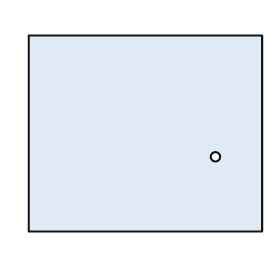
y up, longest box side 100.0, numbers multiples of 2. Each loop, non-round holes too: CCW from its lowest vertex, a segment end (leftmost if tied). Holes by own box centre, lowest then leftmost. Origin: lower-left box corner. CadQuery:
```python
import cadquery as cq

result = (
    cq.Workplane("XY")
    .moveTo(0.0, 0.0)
    .lineTo(100.0, 0.0)
    .lineTo(100.0, 84.0)
    .lineTo(0.0, 84.0)
    .close()
    .moveTo(80.0, 32.0)
    .circle(2.0)
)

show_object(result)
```